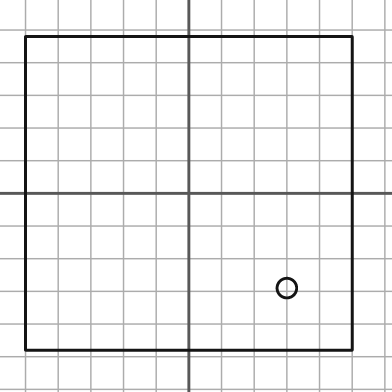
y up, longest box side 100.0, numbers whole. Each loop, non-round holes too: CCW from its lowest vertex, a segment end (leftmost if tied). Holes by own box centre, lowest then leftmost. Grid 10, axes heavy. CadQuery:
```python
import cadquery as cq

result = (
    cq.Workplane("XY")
    .moveTo(-50.0, -48.0)
    .lineTo(50.0, -48.0)
    .lineTo(50.0, 48.0)
    .lineTo(-50.0, 48.0)
    .close()
    .moveTo(30.0, -29.0)
    .circle(3.0)
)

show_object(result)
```